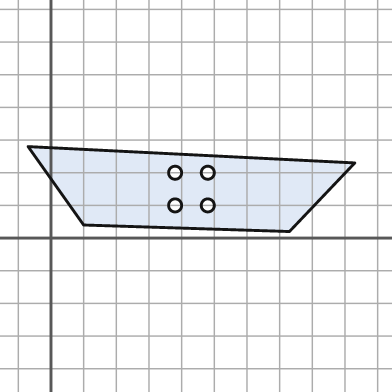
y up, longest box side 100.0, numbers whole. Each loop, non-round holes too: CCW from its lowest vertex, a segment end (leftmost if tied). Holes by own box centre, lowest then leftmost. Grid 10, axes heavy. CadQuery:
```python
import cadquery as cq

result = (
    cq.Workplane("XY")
    .moveTo(73.0, 2.0)
    .lineTo(93.0, 23.0)
    .lineTo(-7.0, 28.0)
    .lineTo(10.0, 4.0)
    .close()
    .moveTo(38.0, 10.0)
    .circle(2.0)
    .moveTo(48.0, 10.0)
    .circle(2.0)
    .moveTo(38.0, 20.0)
    .circle(2.0)
    .moveTo(48.0, 20.0)
    .circle(2.0)
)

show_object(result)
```